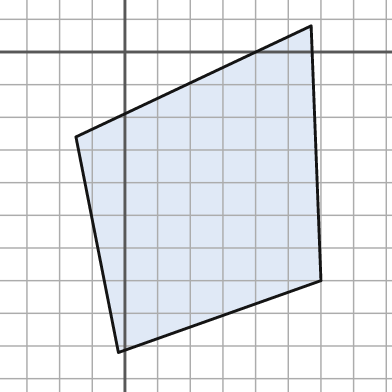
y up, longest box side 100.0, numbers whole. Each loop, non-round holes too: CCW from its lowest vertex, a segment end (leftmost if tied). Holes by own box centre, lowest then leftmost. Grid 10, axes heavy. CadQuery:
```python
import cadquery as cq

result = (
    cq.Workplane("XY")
    .moveTo(-2.0, -92.0)
    .lineTo(60.0, -70.0)
    .lineTo(57.0, 8.0)
    .lineTo(-15.0, -26.0)
    .close()
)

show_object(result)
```